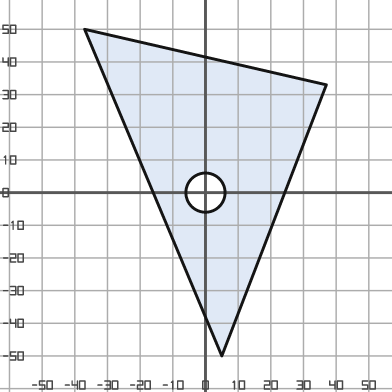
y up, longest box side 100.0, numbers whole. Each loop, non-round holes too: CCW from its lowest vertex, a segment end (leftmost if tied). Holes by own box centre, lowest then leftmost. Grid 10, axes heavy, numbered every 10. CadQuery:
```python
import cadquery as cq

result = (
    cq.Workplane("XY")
    .moveTo(5.0, -50.0)
    .lineTo(37.0, 33.0)
    .lineTo(-37.0, 50.0)
    .close()
    .moveTo(0.0, 0.0)
    .circle(6.0)
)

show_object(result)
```